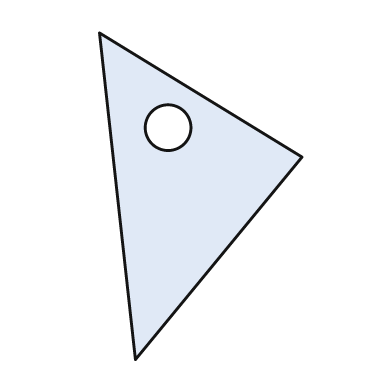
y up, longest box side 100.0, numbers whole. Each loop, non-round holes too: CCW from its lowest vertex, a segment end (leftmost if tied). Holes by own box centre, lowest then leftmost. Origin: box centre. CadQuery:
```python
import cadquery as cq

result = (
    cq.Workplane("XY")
    .moveTo(-20.0, -50.0)
    .lineTo(31.0, 12.0)
    .lineTo(-31.0, 50.0)
    .close()
    .moveTo(-10.0, 21.0)
    .circle(7.0)
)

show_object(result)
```